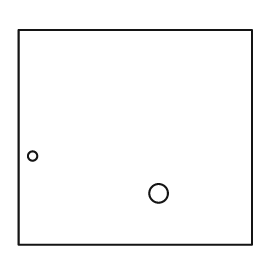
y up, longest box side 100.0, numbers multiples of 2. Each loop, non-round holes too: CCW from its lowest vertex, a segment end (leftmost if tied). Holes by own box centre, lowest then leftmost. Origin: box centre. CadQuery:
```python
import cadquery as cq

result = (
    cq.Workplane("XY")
    .moveTo(-50.0, -46.0)
    .lineTo(50.0, -46.0)
    .lineTo(50.0, 46.0)
    .lineTo(-50.0, 46.0)
    .close()
    .moveTo(10.0, -24.0)
    .circle(4.0)
    .moveTo(-44.0, -8.0)
    .circle(2.0)
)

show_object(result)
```